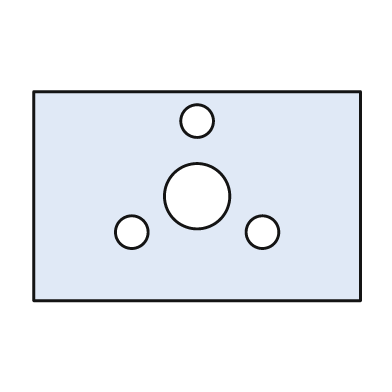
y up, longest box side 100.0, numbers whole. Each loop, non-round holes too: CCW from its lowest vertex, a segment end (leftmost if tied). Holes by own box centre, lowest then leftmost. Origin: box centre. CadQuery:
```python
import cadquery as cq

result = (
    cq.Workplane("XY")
    .moveTo(-50.0, -32.0)
    .lineTo(50.0, -32.0)
    .lineTo(50.0, 32.0)
    .lineTo(-50.0, 32.0)
    .close()
    .moveTo(-20.0, -11.0)
    .circle(5.0)
    .moveTo(20.0, -11.0)
    .circle(5.0)
    .moveTo(0.0, 0.0)
    .circle(10.0)
    .moveTo(0.0, 23.0)
    .circle(5.0)
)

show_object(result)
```